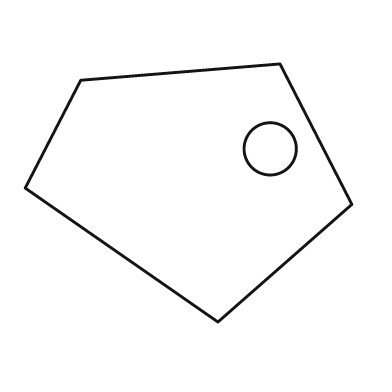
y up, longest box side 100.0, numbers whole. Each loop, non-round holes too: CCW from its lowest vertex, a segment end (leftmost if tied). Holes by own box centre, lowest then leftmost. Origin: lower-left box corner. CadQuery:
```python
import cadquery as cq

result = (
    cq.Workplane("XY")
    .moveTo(59.0, 0.0)
    .lineTo(100.0, 36.0)
    .lineTo(78.0, 79.0)
    .lineTo(17.0, 74.0)
    .lineTo(0.0, 41.0)
    .close()
    .moveTo(75.0, 53.0)
    .circle(8.0)
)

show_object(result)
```